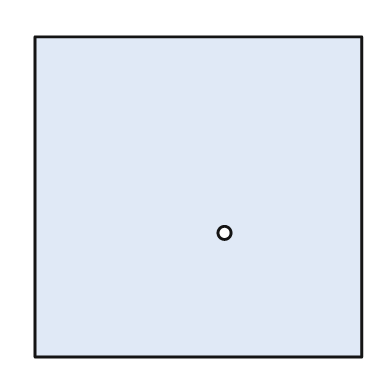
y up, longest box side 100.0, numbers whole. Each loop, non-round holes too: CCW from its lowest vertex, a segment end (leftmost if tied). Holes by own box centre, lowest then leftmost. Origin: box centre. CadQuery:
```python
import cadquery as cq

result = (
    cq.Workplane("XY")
    .moveTo(-50.0, -49.0)
    .lineTo(50.0, -49.0)
    .lineTo(50.0, 49.0)
    .lineTo(-50.0, 49.0)
    .close()
    .moveTo(8.0, -11.0)
    .circle(2.0)
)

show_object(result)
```